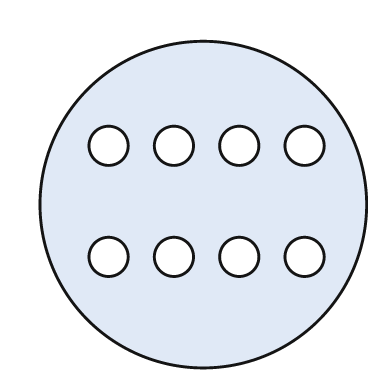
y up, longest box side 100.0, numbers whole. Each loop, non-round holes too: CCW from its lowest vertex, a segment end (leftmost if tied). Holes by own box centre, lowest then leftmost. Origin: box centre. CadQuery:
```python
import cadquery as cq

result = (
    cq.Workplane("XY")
    .moveTo(0.0, 0.0)
    .circle(50.0)
    .moveTo(-29.0, -16.0)
    .circle(6.0)
    .moveTo(-9.0, -16.0)
    .circle(6.0)
    .moveTo(11.0, -16.0)
    .circle(6.0)
    .moveTo(31.0, -16.0)
    .circle(6.0)
    .moveTo(-29.0, 18.0)
    .circle(6.0)
    .moveTo(-9.0, 18.0)
    .circle(6.0)
    .moveTo(11.0, 18.0)
    .circle(6.0)
    .moveTo(31.0, 18.0)
    .circle(6.0)
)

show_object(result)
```